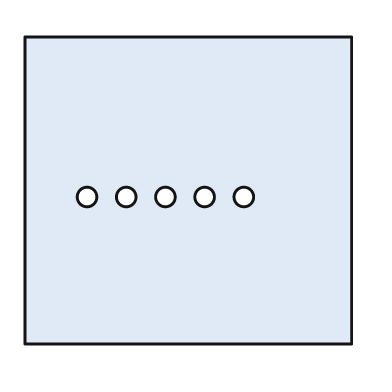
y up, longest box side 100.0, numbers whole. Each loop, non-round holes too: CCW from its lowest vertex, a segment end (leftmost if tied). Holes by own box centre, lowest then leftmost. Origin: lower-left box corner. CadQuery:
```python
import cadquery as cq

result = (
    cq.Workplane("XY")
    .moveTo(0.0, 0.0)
    .lineTo(100.0, 0.0)
    .lineTo(100.0, 94.0)
    .lineTo(0.0, 94.0)
    .close()
    .moveTo(19.0, 45.0)
    .circle(3.0)
    .moveTo(31.0, 45.0)
    .circle(3.0)
    .moveTo(43.0, 45.0)
    .circle(3.0)
    .moveTo(55.0, 45.0)
    .circle(3.0)
    .moveTo(67.0, 45.0)
    .circle(3.0)
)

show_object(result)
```